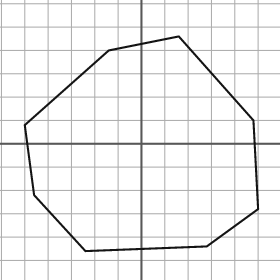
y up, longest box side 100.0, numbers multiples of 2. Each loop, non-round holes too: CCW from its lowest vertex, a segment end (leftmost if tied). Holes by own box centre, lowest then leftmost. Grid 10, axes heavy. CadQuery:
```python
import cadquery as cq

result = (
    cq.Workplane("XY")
    .moveTo(-24.0, -46.0)
    .lineTo(28.0, -44.0)
    .lineTo(50.0, -28.0)
    .lineTo(48.0, 10.0)
    .lineTo(16.0, 46.0)
    .lineTo(-14.0, 40.0)
    .lineTo(-50.0, 8.0)
    .lineTo(-46.0, -22.0)
    .close()
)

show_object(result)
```